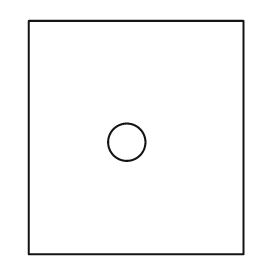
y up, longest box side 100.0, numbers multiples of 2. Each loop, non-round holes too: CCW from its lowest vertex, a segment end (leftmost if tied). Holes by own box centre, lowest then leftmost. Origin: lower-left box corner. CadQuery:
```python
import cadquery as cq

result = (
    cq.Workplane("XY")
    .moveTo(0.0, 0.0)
    .lineTo(92.0, 0.0)
    .lineTo(92.0, 100.0)
    .lineTo(0.0, 100.0)
    .close()
    .moveTo(42.0, 48.0)
    .circle(8.0)
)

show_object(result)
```